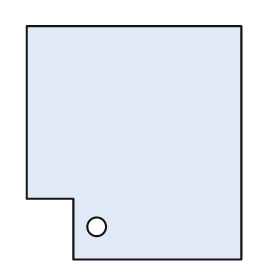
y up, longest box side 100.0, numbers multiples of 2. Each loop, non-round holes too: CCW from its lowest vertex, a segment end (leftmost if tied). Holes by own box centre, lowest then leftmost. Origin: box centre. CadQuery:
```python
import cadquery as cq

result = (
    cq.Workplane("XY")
    .moveTo(-26.0, -50.0)
    .lineTo(46.0, -50.0)
    .lineTo(46.0, 50.0)
    .lineTo(-46.0, 50.0)
    .lineTo(-46.0, -24.0)
    .lineTo(-26.0, -24.0)
    .close()
    .moveTo(-16.0, -36.0)
    .circle(4.0)
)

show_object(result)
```